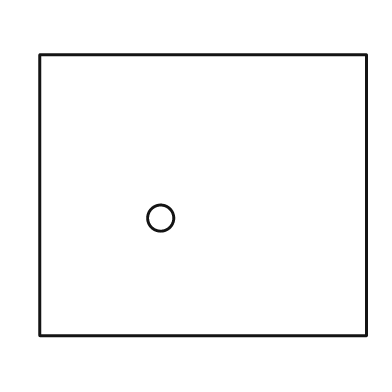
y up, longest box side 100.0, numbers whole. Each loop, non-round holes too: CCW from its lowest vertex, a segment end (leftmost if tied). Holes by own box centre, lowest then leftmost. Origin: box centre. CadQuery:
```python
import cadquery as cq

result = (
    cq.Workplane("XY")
    .moveTo(-50.0, -43.0)
    .lineTo(50.0, -43.0)
    .lineTo(50.0, 43.0)
    .lineTo(-50.0, 43.0)
    .close()
    .moveTo(-13.0, -7.0)
    .circle(4.0)
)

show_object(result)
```